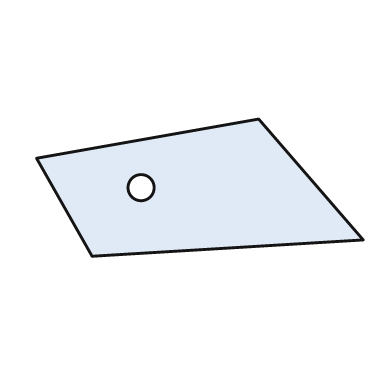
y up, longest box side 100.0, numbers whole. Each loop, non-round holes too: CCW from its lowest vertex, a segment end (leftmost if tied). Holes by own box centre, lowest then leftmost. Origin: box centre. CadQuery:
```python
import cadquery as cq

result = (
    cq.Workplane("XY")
    .moveTo(-33.0, -21.0)
    .lineTo(50.0, -16.0)
    .lineTo(18.0, 21.0)
    .lineTo(-50.0, 9.0)
    .close()
    .moveTo(-18.0, 0.0)
    .circle(4.0)
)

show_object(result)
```